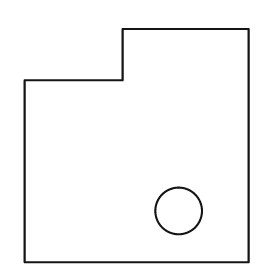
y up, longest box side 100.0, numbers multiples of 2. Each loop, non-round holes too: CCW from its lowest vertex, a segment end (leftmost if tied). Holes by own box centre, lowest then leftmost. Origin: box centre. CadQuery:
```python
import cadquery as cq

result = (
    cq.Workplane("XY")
    .moveTo(-48.0, -50.0)
    .lineTo(48.0, -50.0)
    .lineTo(48.0, 50.0)
    .lineTo(-6.0, 50.0)
    .lineTo(-6.0, 28.0)
    .lineTo(-48.0, 28.0)
    .close()
    .moveTo(18.0, -28.0)
    .circle(10.0)
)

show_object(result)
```